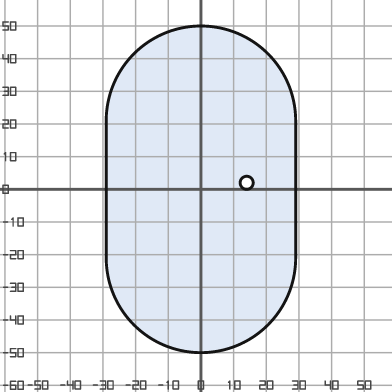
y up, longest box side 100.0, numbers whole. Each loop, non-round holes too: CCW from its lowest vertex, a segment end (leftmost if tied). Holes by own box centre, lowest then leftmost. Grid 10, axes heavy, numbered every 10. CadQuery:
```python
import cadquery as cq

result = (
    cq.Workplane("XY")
    .moveTo(-29.0, -21.0)
    .threePointArc((0.0, -50.0), (29.0, -21.0))
    .lineTo(29.0, 21.0)
    .threePointArc((0.0, 50.0), (-29.0, 21.0))
    .close()
    .moveTo(14.0, 2.0)
    .circle(2.0)
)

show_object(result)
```